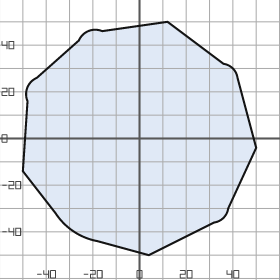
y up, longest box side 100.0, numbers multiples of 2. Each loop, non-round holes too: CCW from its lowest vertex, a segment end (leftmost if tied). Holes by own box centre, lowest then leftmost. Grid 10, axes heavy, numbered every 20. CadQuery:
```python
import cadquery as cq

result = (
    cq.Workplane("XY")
    .moveTo(4.0, -50.0)
    .lineTo(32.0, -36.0)
    .threePointArc((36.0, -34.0), (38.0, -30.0))
    .lineTo(50.0, -4.0)
    .lineTo(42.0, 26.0)
    .threePointArc((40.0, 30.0), (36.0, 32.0))
    .lineTo(12.0, 50.0)
    .lineTo(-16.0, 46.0)
    .threePointArc((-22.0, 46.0), (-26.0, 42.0))
    .lineTo(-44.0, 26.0)
    .threePointArc((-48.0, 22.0), (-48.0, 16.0))
    .lineTo(-50.0, -14.0)
    .lineTo(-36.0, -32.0)
    .threePointArc((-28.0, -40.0), (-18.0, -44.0))
    .close()
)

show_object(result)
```